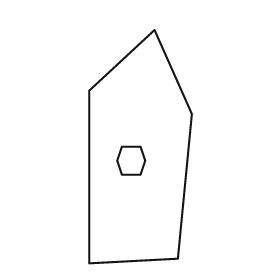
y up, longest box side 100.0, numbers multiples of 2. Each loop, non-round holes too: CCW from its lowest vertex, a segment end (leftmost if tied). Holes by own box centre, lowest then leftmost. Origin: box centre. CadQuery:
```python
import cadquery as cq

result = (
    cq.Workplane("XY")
    .moveTo(-22.0, -50.0)
    .lineTo(16.0, -48.0)
    .lineTo(22.0, 14.0)
    .lineTo(6.0, 50.0)
    .lineTo(-22.0, 24.0)
    .close()
    .moveTo(-8.0, -12.0)
    .lineTo(0.0, -12.0)
    .lineTo(2.0, -6.0)
    .lineTo(0.0, 0.0)
    .lineTo(-8.0, 0.0)
    .lineTo(-10.0, -6.0)
    .close()
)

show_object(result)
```